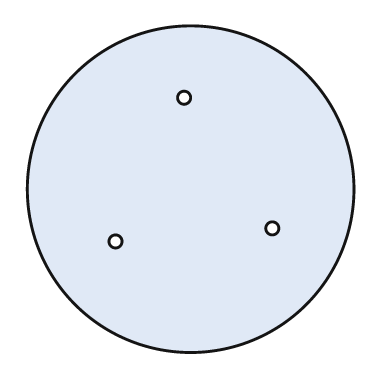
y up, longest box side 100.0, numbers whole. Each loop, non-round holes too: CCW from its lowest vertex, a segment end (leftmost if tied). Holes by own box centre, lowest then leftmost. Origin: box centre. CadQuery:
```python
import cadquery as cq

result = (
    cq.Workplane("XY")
    .moveTo(0.0, 0.0)
    .circle(50.0)
    .moveTo(-23.0, -16.0)
    .circle(2.0)
    .moveTo(25.0, -12.0)
    .circle(2.0)
    .moveTo(-2.0, 28.0)
    .circle(2.0)
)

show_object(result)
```